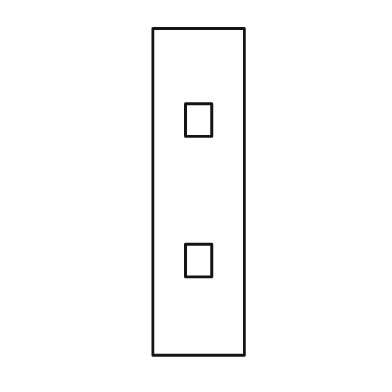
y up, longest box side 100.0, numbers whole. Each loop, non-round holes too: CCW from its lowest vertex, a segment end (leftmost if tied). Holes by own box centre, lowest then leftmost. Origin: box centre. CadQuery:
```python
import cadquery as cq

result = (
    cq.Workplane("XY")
    .moveTo(-14.0, -50.0)
    .lineTo(14.0, -50.0)
    .lineTo(14.0, 50.0)
    .lineTo(-14.0, 50.0)
    .close()
    .moveTo(-4.0, -26.0)
    .lineTo(4.0, -26.0)
    .lineTo(4.0, -16.0)
    .lineTo(-4.0, -16.0)
    .close()
    .moveTo(-4.0, 17.0)
    .lineTo(4.0, 17.0)
    .lineTo(4.0, 27.0)
    .lineTo(-4.0, 27.0)
    .close()
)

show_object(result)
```